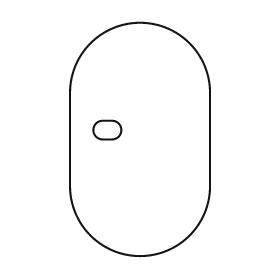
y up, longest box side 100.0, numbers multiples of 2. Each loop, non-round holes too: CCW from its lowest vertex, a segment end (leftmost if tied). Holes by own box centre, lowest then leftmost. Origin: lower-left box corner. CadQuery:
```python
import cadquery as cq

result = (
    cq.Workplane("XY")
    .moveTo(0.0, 30.0)
    .threePointArc((30.0, 0.0), (60.0, 30.0))
    .lineTo(60.0, 70.0)
    .threePointArc((30.0, 100.0), (0.0, 70.0))
    .close()
    .moveTo(14.0, 50.0)
    .lineTo(18.0, 50.0)
    .threePointArc((22.0, 54.0), (18.0, 58.0))
    .lineTo(14.0, 58.0)
    .threePointArc((10.0, 54.0), (14.0, 50.0))
    .close()
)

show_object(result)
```